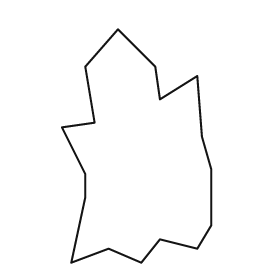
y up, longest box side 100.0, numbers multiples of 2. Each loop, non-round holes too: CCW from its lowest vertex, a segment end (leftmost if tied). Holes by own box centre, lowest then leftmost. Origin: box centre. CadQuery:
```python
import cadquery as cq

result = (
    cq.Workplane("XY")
    .moveTo(-28.0, -50.0)
    .lineTo(-12.0, -44.0)
    .lineTo(2.0, -50.0)
    .lineTo(10.0, -40.0)
    .lineTo(26.0, -44.0)
    .lineTo(32.0, -34.0)
    .lineTo(32.0, -10.0)
    .lineTo(28.0, 4.0)
    .lineTo(26.0, 30.0)
    .lineTo(10.0, 20.0)
    .lineTo(8.0, 34.0)
    .lineTo(-8.0, 50.0)
    .lineTo(-22.0, 34.0)
    .lineTo(-18.0, 10.0)
    .lineTo(-32.0, 8.0)
    .lineTo(-22.0, -12.0)
    .lineTo(-22.0, -22.0)
    .close()
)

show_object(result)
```